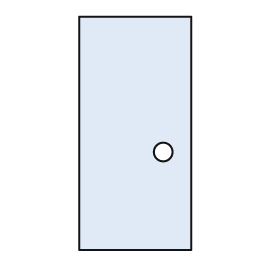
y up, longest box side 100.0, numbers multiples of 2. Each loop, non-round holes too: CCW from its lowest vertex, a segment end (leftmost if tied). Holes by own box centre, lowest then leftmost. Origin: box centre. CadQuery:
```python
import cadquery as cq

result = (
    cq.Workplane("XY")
    .moveTo(-24.0, -50.0)
    .lineTo(24.0, -50.0)
    .lineTo(24.0, 50.0)
    .lineTo(-24.0, 50.0)
    .close()
    .moveTo(12.0, -8.0)
    .circle(4.0)
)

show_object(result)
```